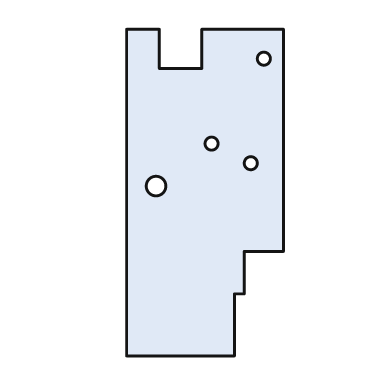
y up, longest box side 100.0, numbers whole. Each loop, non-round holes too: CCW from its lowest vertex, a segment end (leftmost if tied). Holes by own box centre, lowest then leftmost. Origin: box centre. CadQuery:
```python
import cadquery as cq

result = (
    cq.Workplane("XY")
    .moveTo(-24.0, -50.0)
    .lineTo(9.0, -50.0)
    .lineTo(9.0, -31.0)
    .lineTo(12.0, -31.0)
    .lineTo(12.0, -18.0)
    .lineTo(24.0, -18.0)
    .lineTo(24.0, 50.0)
    .lineTo(-1.0, 50.0)
    .lineTo(-1.0, 38.0)
    .lineTo(-14.0, 38.0)
    .lineTo(-14.0, 50.0)
    .lineTo(-24.0, 50.0)
    .close()
    .moveTo(-15.0, 2.0)
    .circle(3.0)
    .moveTo(14.0, 9.0)
    .circle(2.0)
    .moveTo(2.0, 15.0)
    .circle(2.0)
    .moveTo(18.0, 41.0)
    .circle(2.0)
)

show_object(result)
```